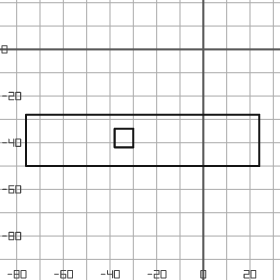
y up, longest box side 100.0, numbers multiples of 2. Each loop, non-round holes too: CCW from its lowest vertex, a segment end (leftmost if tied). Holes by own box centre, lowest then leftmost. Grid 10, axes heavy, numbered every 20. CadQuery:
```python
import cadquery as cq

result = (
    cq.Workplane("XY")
    .moveTo(-76.0, -50.0)
    .lineTo(24.0, -50.0)
    .lineTo(24.0, -28.0)
    .lineTo(-76.0, -28.0)
    .close()
    .moveTo(-38.0, -42.0)
    .lineTo(-30.0, -42.0)
    .lineTo(-30.0, -34.0)
    .lineTo(-38.0, -34.0)
    .close()
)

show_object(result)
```